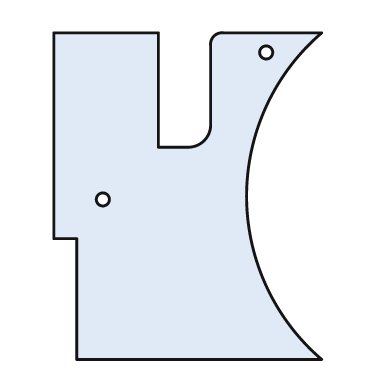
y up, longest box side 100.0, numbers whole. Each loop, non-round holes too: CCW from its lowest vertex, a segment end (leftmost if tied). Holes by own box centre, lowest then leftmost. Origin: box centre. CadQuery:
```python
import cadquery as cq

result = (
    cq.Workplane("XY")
    .moveTo(-34.0, -50.0)
    .lineTo(41.0, -50.0)
    .threePointArc((18.0, 0.0), (41.0, 50.0))
    .lineTo(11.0, 50.0)
    .threePointArc((8.0, 49.0), (7.0, 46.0))
    .lineTo(7.0, 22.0)
    .threePointArc((5.0, 17.0), (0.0, 15.0))
    .lineTo(-9.0, 15.0)
    .lineTo(-9.0, 50.0)
    .lineTo(-41.0, 50.0)
    .lineTo(-41.0, -13.0)
    .lineTo(-34.0, -13.0)
    .close()
    .moveTo(-26.0, -1.0)
    .circle(2.0)
    .moveTo(24.0, 44.0)
    .circle(2.0)
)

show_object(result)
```